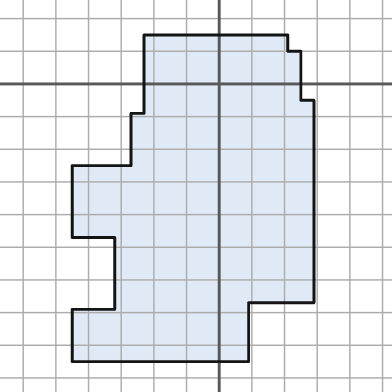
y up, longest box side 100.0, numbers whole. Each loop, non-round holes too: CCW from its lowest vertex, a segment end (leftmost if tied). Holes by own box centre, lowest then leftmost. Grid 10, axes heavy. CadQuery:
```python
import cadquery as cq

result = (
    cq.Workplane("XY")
    .moveTo(-45.0, -85.0)
    .lineTo(9.0, -85.0)
    .lineTo(9.0, -67.0)
    .lineTo(29.0, -67.0)
    .lineTo(29.0, -5.0)
    .lineTo(25.0, -5.0)
    .lineTo(25.0, 10.0)
    .lineTo(21.0, 10.0)
    .lineTo(21.0, 15.0)
    .lineTo(-23.0, 15.0)
    .lineTo(-23.0, -9.0)
    .lineTo(-27.0, -9.0)
    .lineTo(-27.0, -25.0)
    .lineTo(-45.0, -25.0)
    .lineTo(-45.0, -47.0)
    .lineTo(-32.0, -47.0)
    .lineTo(-32.0, -69.0)
    .lineTo(-45.0, -69.0)
    .close()
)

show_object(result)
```